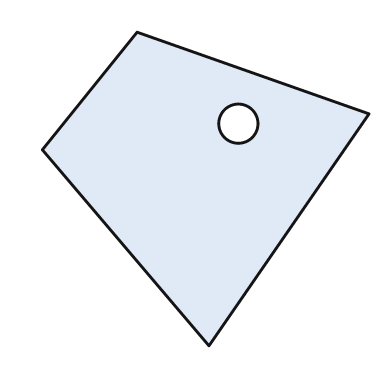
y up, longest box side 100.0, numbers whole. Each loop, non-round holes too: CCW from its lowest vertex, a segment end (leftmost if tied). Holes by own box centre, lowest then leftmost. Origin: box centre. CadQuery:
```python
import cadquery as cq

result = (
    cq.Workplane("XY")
    .moveTo(1.0, -48.0)
    .lineTo(50.0, 23.0)
    .lineTo(-21.0, 48.0)
    .lineTo(-50.0, 12.0)
    .close()
    .moveTo(10.0, 20.0)
    .circle(6.0)
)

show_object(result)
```